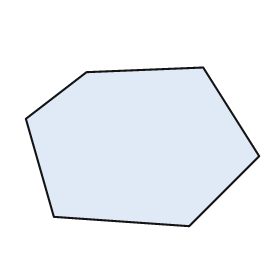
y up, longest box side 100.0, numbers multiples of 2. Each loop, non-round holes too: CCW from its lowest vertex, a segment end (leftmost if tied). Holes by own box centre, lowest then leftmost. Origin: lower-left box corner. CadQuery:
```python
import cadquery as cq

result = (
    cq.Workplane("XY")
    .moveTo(70.0, 0.0)
    .lineTo(100.0, 30.0)
    .lineTo(76.0, 68.0)
    .lineTo(26.0, 66.0)
    .lineTo(0.0, 46.0)
    .lineTo(12.0, 4.0)
    .close()
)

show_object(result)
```